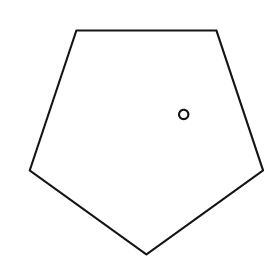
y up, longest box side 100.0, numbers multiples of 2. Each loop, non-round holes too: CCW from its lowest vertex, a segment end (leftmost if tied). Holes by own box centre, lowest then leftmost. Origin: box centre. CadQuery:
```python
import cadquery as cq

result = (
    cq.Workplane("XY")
    .moveTo(0.0, -48.0)
    .lineTo(50.0, -12.0)
    .lineTo(30.0, 48.0)
    .lineTo(-30.0, 48.0)
    .lineTo(-50.0, -12.0)
    .close()
    .moveTo(16.0, 12.0)
    .circle(2.0)
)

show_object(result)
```